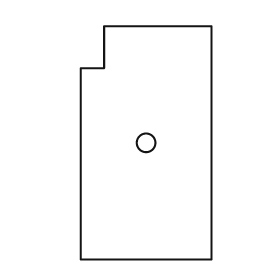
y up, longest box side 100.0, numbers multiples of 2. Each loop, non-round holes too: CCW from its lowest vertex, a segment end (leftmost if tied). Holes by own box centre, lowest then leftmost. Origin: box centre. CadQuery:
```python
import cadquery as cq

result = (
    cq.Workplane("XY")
    .moveTo(-28.0, -50.0)
    .lineTo(28.0, -50.0)
    .lineTo(28.0, 50.0)
    .lineTo(-18.0, 50.0)
    .lineTo(-18.0, 32.0)
    .lineTo(-28.0, 32.0)
    .close()
    .moveTo(0.0, 0.0)
    .circle(4.0)
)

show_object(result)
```